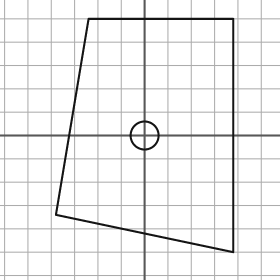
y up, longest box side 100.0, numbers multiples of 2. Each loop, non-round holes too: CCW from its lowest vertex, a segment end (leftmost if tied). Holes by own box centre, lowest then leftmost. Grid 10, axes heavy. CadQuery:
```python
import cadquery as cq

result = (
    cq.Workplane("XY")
    .moveTo(38.0, -50.0)
    .lineTo(38.0, 50.0)
    .lineTo(-24.0, 50.0)
    .lineTo(-38.0, -34.0)
    .close()
    .moveTo(0.0, 0.0)
    .circle(6.0)
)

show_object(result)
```